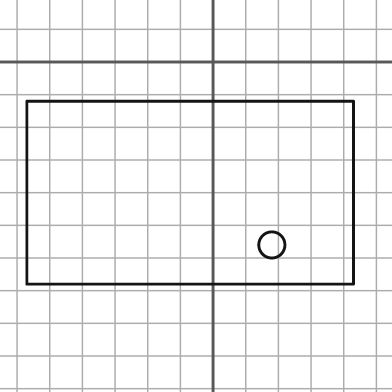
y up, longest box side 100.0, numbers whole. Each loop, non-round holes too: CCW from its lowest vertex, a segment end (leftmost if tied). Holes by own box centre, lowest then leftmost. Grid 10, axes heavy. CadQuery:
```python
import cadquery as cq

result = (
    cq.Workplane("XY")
    .moveTo(-57.0, -68.0)
    .lineTo(43.0, -68.0)
    .lineTo(43.0, -12.0)
    .lineTo(-57.0, -12.0)
    .close()
    .moveTo(18.0, -56.0)
    .circle(4.0)
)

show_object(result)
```